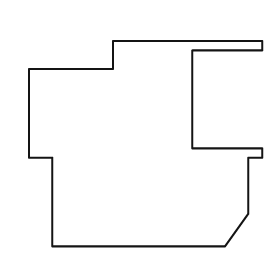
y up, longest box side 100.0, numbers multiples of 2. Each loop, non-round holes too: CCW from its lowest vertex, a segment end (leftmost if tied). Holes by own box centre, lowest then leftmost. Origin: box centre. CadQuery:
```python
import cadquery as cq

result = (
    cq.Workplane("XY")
    .moveTo(-40.0, -44.0)
    .lineTo(34.0, -44.0)
    .lineTo(44.0, -30.0)
    .lineTo(44.0, -6.0)
    .lineTo(50.0, -6.0)
    .lineTo(50.0, -2.0)
    .lineTo(20.0, -2.0)
    .lineTo(20.0, 40.0)
    .lineTo(50.0, 40.0)
    .lineTo(50.0, 44.0)
    .lineTo(-14.0, 44.0)
    .lineTo(-14.0, 32.0)
    .lineTo(-50.0, 32.0)
    .lineTo(-50.0, -6.0)
    .lineTo(-40.0, -6.0)
    .close()
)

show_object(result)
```